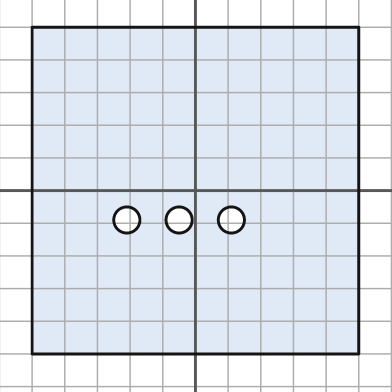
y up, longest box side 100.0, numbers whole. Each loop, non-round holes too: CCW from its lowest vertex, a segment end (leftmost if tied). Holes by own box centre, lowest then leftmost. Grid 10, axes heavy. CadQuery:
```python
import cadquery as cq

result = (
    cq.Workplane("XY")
    .moveTo(-50.0, -50.0)
    .lineTo(50.0, -50.0)
    .lineTo(50.0, 50.0)
    .lineTo(-50.0, 50.0)
    .close()
    .moveTo(-21.0, -9.0)
    .circle(4.0)
    .moveTo(-5.0, -9.0)
    .circle(4.0)
    .moveTo(11.0, -9.0)
    .circle(4.0)
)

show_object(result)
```